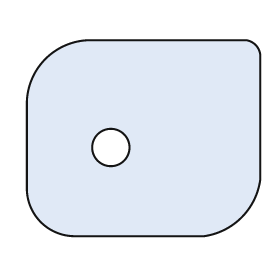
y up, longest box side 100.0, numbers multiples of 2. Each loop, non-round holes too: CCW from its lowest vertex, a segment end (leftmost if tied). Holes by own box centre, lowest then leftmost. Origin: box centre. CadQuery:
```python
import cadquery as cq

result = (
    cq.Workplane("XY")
    .moveTo(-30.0, -42.0)
    .lineTo(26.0, -42.0)
    .threePointArc((42.0, -34.0), (50.0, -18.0))
    .lineTo(50.0, 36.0)
    .threePointArc((48.0, 40.0), (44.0, 42.0))
    .lineTo(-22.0, 42.0)
    .threePointArc((-42.0, 34.0), (-50.0, 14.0))
    .lineTo(-50.0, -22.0)
    .threePointArc((-44.0, -36.0), (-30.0, -42.0))
    .close()
    .moveTo(-14.0, -4.0)
    .circle(8.0)
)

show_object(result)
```